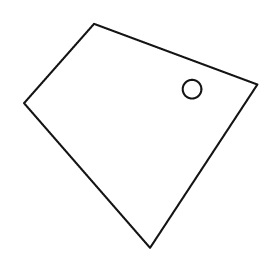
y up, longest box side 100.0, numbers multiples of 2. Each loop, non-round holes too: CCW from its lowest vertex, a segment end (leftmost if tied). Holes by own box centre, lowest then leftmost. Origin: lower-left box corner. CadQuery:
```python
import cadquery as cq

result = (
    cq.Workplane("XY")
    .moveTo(54.0, 0.0)
    .lineTo(100.0, 70.0)
    .lineTo(30.0, 96.0)
    .lineTo(0.0, 62.0)
    .close()
    .moveTo(72.0, 68.0)
    .circle(4.0)
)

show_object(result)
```